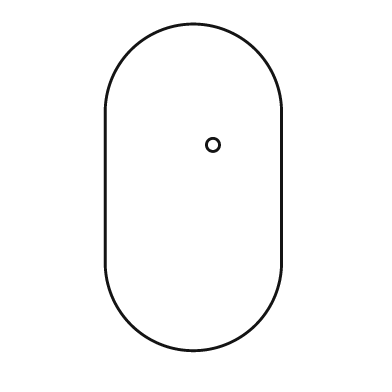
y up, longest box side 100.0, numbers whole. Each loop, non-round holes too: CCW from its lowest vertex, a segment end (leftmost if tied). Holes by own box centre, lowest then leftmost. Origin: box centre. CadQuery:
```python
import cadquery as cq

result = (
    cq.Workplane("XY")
    .moveTo(-27.0, -23.0)
    .threePointArc((0.0, -50.0), (27.0, -23.0))
    .lineTo(27.0, 23.0)
    .threePointArc((0.0, 50.0), (-27.0, 23.0))
    .close()
    .moveTo(6.0, 13.0)
    .circle(2.0)
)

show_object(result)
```